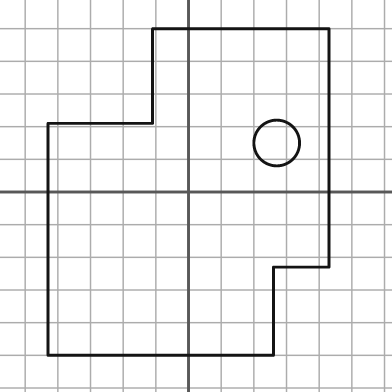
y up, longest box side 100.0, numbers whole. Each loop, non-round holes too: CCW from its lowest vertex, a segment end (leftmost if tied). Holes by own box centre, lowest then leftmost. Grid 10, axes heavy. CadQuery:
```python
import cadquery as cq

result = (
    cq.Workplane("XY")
    .moveTo(-43.0, -50.0)
    .lineTo(26.0, -50.0)
    .lineTo(26.0, -23.0)
    .lineTo(43.0, -23.0)
    .lineTo(43.0, 50.0)
    .lineTo(-11.0, 50.0)
    .lineTo(-11.0, 21.0)
    .lineTo(-43.0, 21.0)
    .close()
    .moveTo(27.0, 15.0)
    .circle(7.0)
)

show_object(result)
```